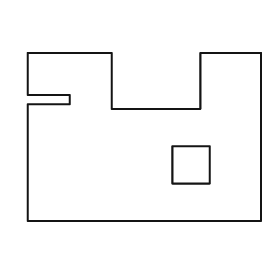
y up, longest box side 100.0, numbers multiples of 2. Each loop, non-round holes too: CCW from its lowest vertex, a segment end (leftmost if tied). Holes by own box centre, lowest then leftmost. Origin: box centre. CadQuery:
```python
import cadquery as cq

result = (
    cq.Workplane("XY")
    .moveTo(-50.0, -36.0)
    .lineTo(50.0, -36.0)
    .lineTo(50.0, 36.0)
    .lineTo(24.0, 36.0)
    .lineTo(24.0, 12.0)
    .lineTo(-14.0, 12.0)
    .lineTo(-14.0, 36.0)
    .lineTo(-50.0, 36.0)
    .lineTo(-50.0, 18.0)
    .lineTo(-32.0, 18.0)
    .lineTo(-32.0, 14.0)
    .lineTo(-50.0, 14.0)
    .close()
    .moveTo(12.0, -20.0)
    .lineTo(28.0, -20.0)
    .lineTo(28.0, -4.0)
    .lineTo(12.0, -4.0)
    .close()
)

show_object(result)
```